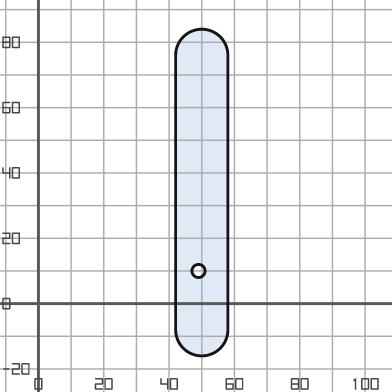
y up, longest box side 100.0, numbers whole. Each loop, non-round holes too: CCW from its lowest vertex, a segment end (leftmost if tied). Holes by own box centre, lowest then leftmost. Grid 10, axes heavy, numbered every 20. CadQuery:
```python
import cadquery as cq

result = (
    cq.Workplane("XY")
    .moveTo(42.0, -8.0)
    .threePointArc((50.0, -16.0), (58.0, -8.0))
    .lineTo(58.0, 76.0)
    .threePointArc((50.0, 84.0), (42.0, 76.0))
    .close()
    .moveTo(49.0, 10.0)
    .circle(2.0)
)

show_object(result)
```